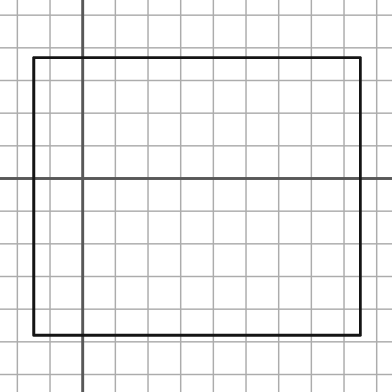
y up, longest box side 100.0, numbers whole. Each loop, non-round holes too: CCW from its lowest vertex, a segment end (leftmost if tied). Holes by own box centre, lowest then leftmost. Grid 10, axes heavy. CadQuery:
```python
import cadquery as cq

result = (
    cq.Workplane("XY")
    .moveTo(-15.0, -48.0)
    .lineTo(85.0, -48.0)
    .lineTo(85.0, 37.0)
    .lineTo(-15.0, 37.0)
    .close()
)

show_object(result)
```